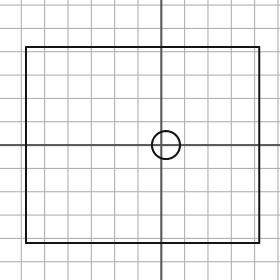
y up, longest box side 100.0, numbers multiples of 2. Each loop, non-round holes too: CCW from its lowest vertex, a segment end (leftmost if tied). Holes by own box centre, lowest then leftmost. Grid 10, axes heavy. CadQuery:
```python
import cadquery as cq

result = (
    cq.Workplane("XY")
    .moveTo(-58.0, -42.0)
    .lineTo(42.0, -42.0)
    .lineTo(42.0, 42.0)
    .lineTo(-58.0, 42.0)
    .close()
    .moveTo(2.0, 0.0)
    .circle(6.0)
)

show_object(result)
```